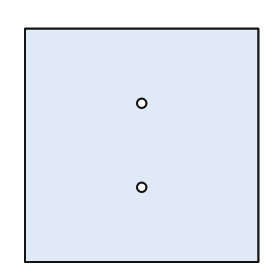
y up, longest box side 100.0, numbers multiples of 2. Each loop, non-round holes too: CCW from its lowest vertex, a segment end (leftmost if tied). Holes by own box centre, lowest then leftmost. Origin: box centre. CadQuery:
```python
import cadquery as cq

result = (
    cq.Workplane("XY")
    .moveTo(-50.0, -50.0)
    .lineTo(50.0, -50.0)
    .lineTo(50.0, 50.0)
    .lineTo(-50.0, 50.0)
    .close()
    .moveTo(0.0, -18.0)
    .circle(2.0)
    .moveTo(0.0, 18.0)
    .circle(2.0)
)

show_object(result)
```